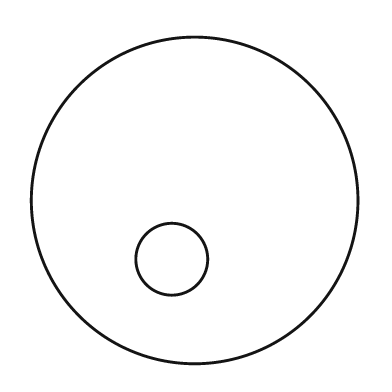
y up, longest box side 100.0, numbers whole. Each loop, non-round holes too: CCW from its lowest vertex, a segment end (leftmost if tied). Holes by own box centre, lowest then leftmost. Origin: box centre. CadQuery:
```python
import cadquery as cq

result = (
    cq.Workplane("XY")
    .moveTo(0.0, 0.0)
    .circle(50.0)
    .moveTo(-7.0, -18.0)
    .circle(11.0)
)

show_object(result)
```